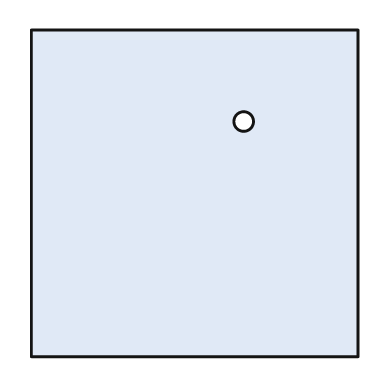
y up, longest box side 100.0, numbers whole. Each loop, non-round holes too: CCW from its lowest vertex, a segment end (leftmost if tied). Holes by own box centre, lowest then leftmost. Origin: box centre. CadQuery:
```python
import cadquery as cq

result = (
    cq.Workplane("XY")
    .moveTo(-50.0, -50.0)
    .lineTo(50.0, -50.0)
    .lineTo(50.0, 50.0)
    .lineTo(-50.0, 50.0)
    .close()
    .moveTo(15.0, 22.0)
    .circle(3.0)
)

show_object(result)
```